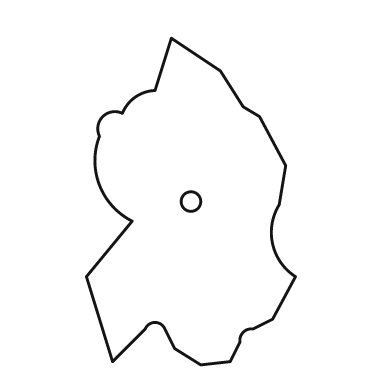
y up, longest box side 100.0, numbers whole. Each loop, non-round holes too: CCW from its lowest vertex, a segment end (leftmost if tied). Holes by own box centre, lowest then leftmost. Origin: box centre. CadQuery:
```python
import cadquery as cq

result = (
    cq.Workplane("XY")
    .moveTo(3.0, -50.0)
    .lineTo(12.0, -49.0)
    .lineTo(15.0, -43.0)
    .threePointArc((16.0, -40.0), (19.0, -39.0))
    .lineTo(25.0, -36.0)
    .lineTo(32.0, -23.0)
    .threePointArc((25.0, -13.0), (27.0, -1.0))
    .lineTo(29.0, 11.0)
    .lineTo(21.0, 26.0)
    .lineTo(16.0, 29.0)
    .lineTo(9.0, 40.0)
    .lineTo(-6.0, 50.0)
    .lineTo(-11.0, 34.0)
    .threePointArc((-17.0, 32.0), (-21.0, 27.0))
    .threePointArc((-27.0, 26.0), (-28.0, 20.0))
    .threePointArc((-28.0, 5.0), (-18.0, -6.0))
    .lineTo(-32.0, -23.0)
    .lineTo(-24.0, -49.0)
    .lineTo(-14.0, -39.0)
    .threePointArc((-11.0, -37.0), (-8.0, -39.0))
    .lineTo(-5.0, -45.0)
    .close()
    .moveTo(0.0, 0.0)
    .circle(3.0)
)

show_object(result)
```